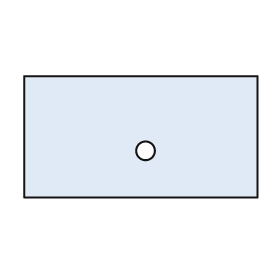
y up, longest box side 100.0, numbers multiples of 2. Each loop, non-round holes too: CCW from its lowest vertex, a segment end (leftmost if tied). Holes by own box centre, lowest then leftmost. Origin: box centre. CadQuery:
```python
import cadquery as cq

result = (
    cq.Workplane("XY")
    .moveTo(-50.0, -26.0)
    .lineTo(50.0, -26.0)
    .lineTo(50.0, 26.0)
    .lineTo(-50.0, 26.0)
    .close()
    .moveTo(2.0, -6.0)
    .circle(4.0)
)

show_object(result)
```